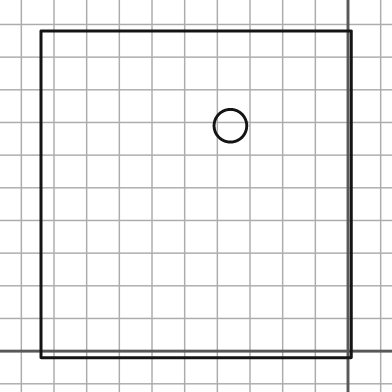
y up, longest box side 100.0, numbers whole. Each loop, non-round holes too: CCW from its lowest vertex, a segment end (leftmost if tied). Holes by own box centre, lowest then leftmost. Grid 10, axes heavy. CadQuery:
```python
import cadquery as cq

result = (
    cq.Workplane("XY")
    .moveTo(-94.0, -2.0)
    .lineTo(1.0, -2.0)
    .lineTo(1.0, 98.0)
    .lineTo(-94.0, 98.0)
    .close()
    .moveTo(-36.0, 69.0)
    .circle(5.0)
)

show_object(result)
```